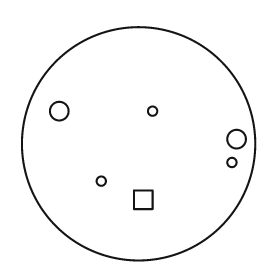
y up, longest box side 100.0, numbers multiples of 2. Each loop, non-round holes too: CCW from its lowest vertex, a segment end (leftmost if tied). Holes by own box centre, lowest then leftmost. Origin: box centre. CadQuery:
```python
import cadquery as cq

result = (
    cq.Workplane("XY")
    .moveTo(0.0, 0.0)
    .circle(50.0)
    .moveTo(-2.0, -28.0)
    .lineTo(6.0, -28.0)
    .lineTo(6.0, -20.0)
    .lineTo(-2.0, -20.0)
    .close()
    .moveTo(-16.0, -16.0)
    .circle(2.0)
    .moveTo(40.0, -8.0)
    .circle(2.0)
    .moveTo(42.0, 2.0)
    .circle(4.0)
    .moveTo(-34.0, 14.0)
    .circle(4.0)
    .moveTo(6.0, 14.0)
    .circle(2.0)
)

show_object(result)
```